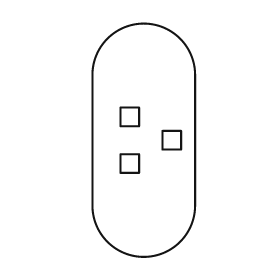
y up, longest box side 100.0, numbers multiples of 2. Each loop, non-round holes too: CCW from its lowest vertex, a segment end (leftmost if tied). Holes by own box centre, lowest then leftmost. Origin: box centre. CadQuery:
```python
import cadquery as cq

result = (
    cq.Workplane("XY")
    .moveTo(-22.0, -28.0)
    .threePointArc((0.0, -50.0), (22.0, -28.0))
    .lineTo(22.0, 28.0)
    .threePointArc((0.0, 50.0), (-22.0, 28.0))
    .close()
    .moveTo(-10.0, -14.0)
    .lineTo(-2.0, -14.0)
    .lineTo(-2.0, -6.0)
    .lineTo(-10.0, -6.0)
    .close()
    .moveTo(8.0, -4.0)
    .lineTo(16.0, -4.0)
    .lineTo(16.0, 4.0)
    .lineTo(8.0, 4.0)
    .close()
    .moveTo(-10.0, 6.0)
    .lineTo(-2.0, 6.0)
    .lineTo(-2.0, 14.0)
    .lineTo(-10.0, 14.0)
    .close()
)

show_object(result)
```